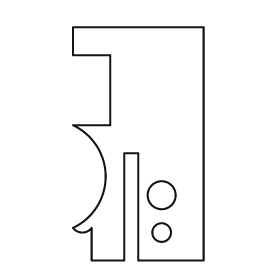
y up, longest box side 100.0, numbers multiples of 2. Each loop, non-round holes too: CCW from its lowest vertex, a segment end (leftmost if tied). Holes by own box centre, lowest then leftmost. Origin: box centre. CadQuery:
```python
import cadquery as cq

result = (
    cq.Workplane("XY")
    .moveTo(-20.0, -50.0)
    .lineTo(-6.0, -50.0)
    .lineTo(-6.0, -4.0)
    .lineTo(0.0, -4.0)
    .lineTo(0.0, -50.0)
    .lineTo(28.0, -50.0)
    .lineTo(28.0, 50.0)
    .lineTo(-28.0, 50.0)
    .lineTo(-28.0, 38.0)
    .lineTo(-12.0, 38.0)
    .lineTo(-12.0, 8.0)
    .lineTo(-28.0, 8.0)
    .threePointArc((-14.0, -14.0), (-28.0, -36.0))
    .threePointArc((-24.0, -38.0), (-20.0, -36.0))
    .close()
    .moveTo(10.0, -38.0)
    .circle(4.0)
    .moveTo(10.0, -22.0)
    .circle(6.0)
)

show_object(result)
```